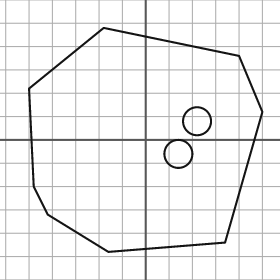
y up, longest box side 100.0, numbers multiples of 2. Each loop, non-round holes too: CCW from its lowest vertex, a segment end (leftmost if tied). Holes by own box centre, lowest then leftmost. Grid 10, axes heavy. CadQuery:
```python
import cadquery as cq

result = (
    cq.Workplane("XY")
    .moveTo(-16.0, -48.0)
    .lineTo(34.0, -44.0)
    .lineTo(50.0, 12.0)
    .lineTo(40.0, 36.0)
    .lineTo(-18.0, 48.0)
    .lineTo(-50.0, 22.0)
    .lineTo(-48.0, -20.0)
    .lineTo(-42.0, -32.0)
    .close()
    .moveTo(14.0, -6.0)
    .circle(6.0)
    .moveTo(22.0, 8.0)
    .circle(6.0)
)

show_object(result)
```